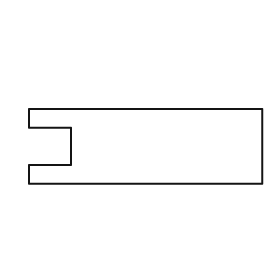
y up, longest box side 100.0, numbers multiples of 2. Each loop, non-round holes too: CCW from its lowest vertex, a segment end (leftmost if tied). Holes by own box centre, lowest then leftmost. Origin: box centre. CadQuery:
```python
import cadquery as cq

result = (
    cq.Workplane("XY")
    .moveTo(-50.0, -16.0)
    .lineTo(50.0, -16.0)
    .lineTo(50.0, 16.0)
    .lineTo(-50.0, 16.0)
    .lineTo(-50.0, 8.0)
    .lineTo(-32.0, 8.0)
    .lineTo(-32.0, -8.0)
    .lineTo(-50.0, -8.0)
    .close()
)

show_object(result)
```